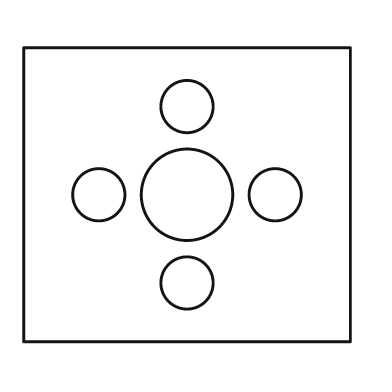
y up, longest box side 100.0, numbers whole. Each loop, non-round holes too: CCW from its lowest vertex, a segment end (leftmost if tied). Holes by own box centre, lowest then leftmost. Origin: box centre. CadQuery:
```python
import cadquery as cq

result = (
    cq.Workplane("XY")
    .moveTo(-50.0, -45.0)
    .lineTo(50.0, -45.0)
    .lineTo(50.0, 45.0)
    .lineTo(-50.0, 45.0)
    .close()
    .moveTo(0.0, -27.0)
    .circle(8.0)
    .moveTo(-27.0, 0.0)
    .circle(8.0)
    .moveTo(0.0, 0.0)
    .circle(14.0)
    .moveTo(27.0, 0.0)
    .circle(8.0)
    .moveTo(0.0, 27.0)
    .circle(8.0)
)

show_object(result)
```